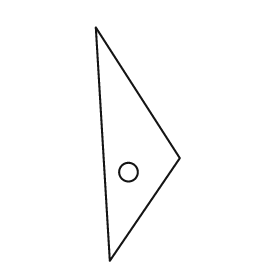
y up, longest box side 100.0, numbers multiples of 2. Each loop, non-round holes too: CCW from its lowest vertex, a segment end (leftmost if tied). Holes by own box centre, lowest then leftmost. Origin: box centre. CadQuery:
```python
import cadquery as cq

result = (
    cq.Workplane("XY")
    .moveTo(-12.0, -50.0)
    .lineTo(18.0, -6.0)
    .lineTo(-18.0, 50.0)
    .close()
    .moveTo(-4.0, -12.0)
    .circle(4.0)
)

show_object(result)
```